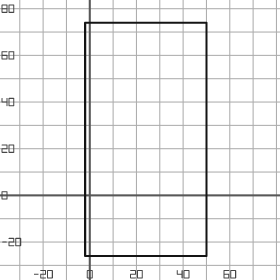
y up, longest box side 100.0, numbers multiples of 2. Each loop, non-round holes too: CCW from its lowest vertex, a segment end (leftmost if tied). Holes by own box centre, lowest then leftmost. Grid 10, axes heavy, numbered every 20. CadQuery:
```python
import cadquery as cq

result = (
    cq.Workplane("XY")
    .moveTo(-2.0, -26.0)
    .lineTo(50.0, -26.0)
    .lineTo(50.0, 74.0)
    .lineTo(-2.0, 74.0)
    .close()
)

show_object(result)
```